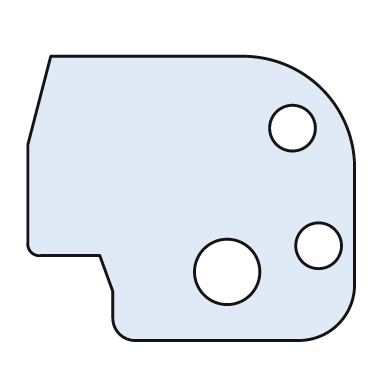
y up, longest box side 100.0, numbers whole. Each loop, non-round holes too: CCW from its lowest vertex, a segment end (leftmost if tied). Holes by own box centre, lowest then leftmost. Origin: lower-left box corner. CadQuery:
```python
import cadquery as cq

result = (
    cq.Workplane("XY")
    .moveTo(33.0, 0.0)
    .lineTo(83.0, 0.0)
    .threePointArc((95.0, 5.0), (100.0, 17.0))
    .lineTo(100.0, 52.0)
    .threePointArc((90.0, 77.0), (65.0, 87.0))
    .lineTo(7.0, 87.0)
    .lineTo(0.0, 60.0)
    .lineTo(0.0, 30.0)
    .threePointArc((1.0, 27.0), (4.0, 26.0))
    .lineTo(22.0, 26.0)
    .lineTo(26.0, 15.0)
    .lineTo(26.0, 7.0)
    .threePointArc((28.0, 2.0), (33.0, 0.0))
    .close()
    .moveTo(61.0, 21.0)
    .circle(10.0)
    .moveTo(89.0, 29.0)
    .circle(7.0)
    .moveTo(81.0, 65.0)
    .circle(7.0)
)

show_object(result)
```